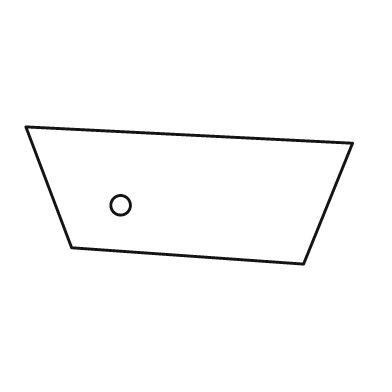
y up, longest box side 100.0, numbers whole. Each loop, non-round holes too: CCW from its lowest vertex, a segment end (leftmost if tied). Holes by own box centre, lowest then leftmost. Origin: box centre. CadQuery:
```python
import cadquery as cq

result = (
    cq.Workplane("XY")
    .moveTo(35.0, -21.0)
    .lineTo(50.0, 16.0)
    .lineTo(-50.0, 21.0)
    .lineTo(-36.0, -16.0)
    .close()
    .moveTo(-21.0, -3.0)
    .circle(3.0)
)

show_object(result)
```